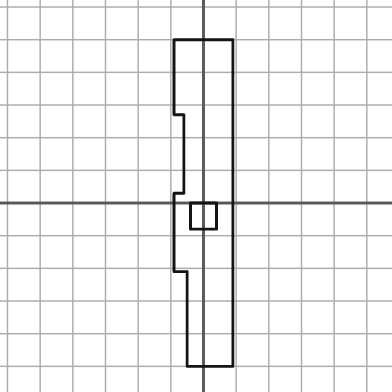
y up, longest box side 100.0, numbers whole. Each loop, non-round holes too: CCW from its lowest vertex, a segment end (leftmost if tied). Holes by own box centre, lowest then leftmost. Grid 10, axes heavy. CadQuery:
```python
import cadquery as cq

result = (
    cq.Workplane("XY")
    .moveTo(-5.0, -50.0)
    .lineTo(9.0, -50.0)
    .lineTo(9.0, 50.0)
    .lineTo(-9.0, 50.0)
    .lineTo(-9.0, 27.0)
    .lineTo(-6.0, 27.0)
    .lineTo(-6.0, 3.0)
    .lineTo(-9.0, 3.0)
    .lineTo(-9.0, -21.0)
    .lineTo(-5.0, -21.0)
    .close()
    .moveTo(-4.0, -8.0)
    .lineTo(4.0, -8.0)
    .lineTo(4.0, 0.0)
    .lineTo(-4.0, 0.0)
    .close()
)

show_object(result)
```